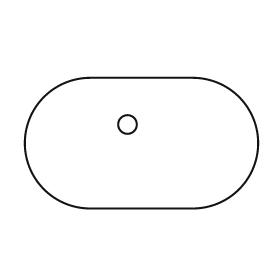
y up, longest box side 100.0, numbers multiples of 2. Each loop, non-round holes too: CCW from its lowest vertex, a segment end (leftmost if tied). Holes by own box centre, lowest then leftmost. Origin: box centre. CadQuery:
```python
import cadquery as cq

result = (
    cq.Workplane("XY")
    .moveTo(-22.0, -28.0)
    .lineTo(22.0, -28.0)
    .threePointArc((50.0, 0.0), (22.0, 28.0))
    .lineTo(-22.0, 28.0)
    .threePointArc((-50.0, 0.0), (-22.0, -28.0))
    .close()
    .moveTo(-6.0, 8.0)
    .circle(4.0)
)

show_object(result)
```